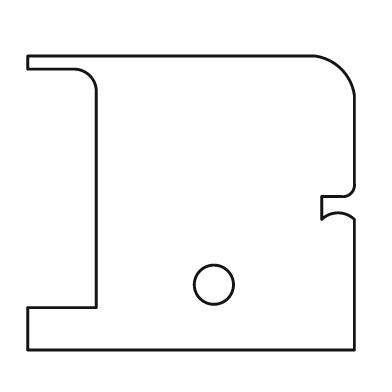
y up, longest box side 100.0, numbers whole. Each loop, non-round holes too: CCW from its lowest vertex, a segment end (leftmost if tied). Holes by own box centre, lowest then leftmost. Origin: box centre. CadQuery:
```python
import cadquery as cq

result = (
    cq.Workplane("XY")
    .moveTo(-50.0, -45.0)
    .lineTo(50.0, -45.0)
    .lineTo(50.0, -5.0)
    .threePointArc((45.0, -3.0), (40.0, -5.0))
    .lineTo(40.0, 2.0)
    .lineTo(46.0, 2.0)
    .threePointArc((49.0, 3.0), (50.0, 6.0))
    .lineTo(50.0, 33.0)
    .threePointArc((46.0, 41.0), (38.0, 45.0))
    .lineTo(-50.0, 45.0)
    .lineTo(-50.0, 41.0)
    .lineTo(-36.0, 41.0)
    .threePointArc((-31.0, 39.0), (-29.0, 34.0))
    .lineTo(-29.0, -32.0)
    .lineTo(-50.0, -32.0)
    .close()
    .moveTo(7.0, -25.0)
    .circle(6.0)
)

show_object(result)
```